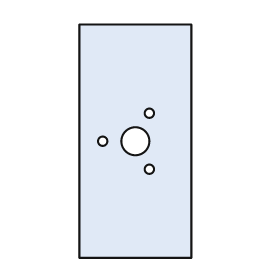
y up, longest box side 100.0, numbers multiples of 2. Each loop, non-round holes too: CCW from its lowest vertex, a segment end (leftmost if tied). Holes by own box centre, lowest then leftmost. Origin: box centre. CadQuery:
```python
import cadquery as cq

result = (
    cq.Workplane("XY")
    .moveTo(-24.0, -50.0)
    .lineTo(24.0, -50.0)
    .lineTo(24.0, 50.0)
    .lineTo(-24.0, 50.0)
    .close()
    .moveTo(6.0, -12.0)
    .circle(2.0)
    .moveTo(-14.0, 0.0)
    .circle(2.0)
    .moveTo(0.0, 0.0)
    .circle(6.0)
    .moveTo(6.0, 12.0)
    .circle(2.0)
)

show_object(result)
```